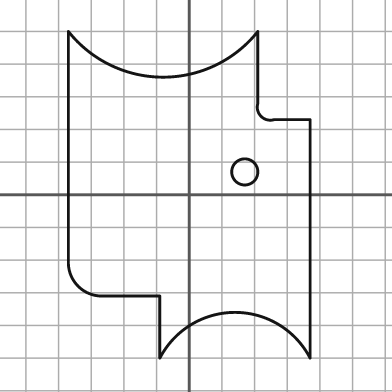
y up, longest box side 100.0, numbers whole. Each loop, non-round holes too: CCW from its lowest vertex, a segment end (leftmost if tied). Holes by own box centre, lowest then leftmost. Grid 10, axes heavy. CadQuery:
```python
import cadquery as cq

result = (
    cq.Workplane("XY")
    .moveTo(-9.0, -50.0)
    .threePointArc((14.0, -36.0), (37.0, -50.0))
    .lineTo(37.0, 23.0)
    .lineTo(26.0, 23.0)
    .threePointArc((22.0, 24.0), (21.0, 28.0))
    .lineTo(21.0, 50.0)
    .threePointArc((-8.0, 36.0), (-37.0, 50.0))
    .lineTo(-37.0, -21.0)
    .threePointArc((-34.0, -28.0), (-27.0, -31.0))
    .lineTo(-9.0, -31.0)
    .close()
    .moveTo(17.0, 7.0)
    .circle(4.0)
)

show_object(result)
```